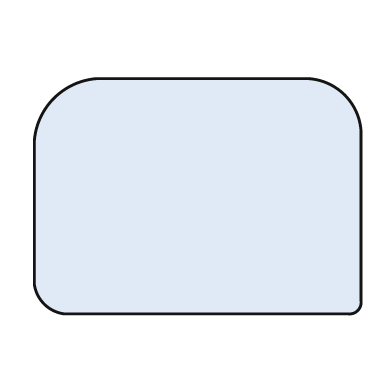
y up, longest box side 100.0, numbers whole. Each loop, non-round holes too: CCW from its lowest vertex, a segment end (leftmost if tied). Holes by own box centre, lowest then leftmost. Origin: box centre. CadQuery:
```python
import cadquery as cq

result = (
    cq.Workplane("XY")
    .moveTo(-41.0, -36.0)
    .lineTo(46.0, -36.0)
    .threePointArc((49.0, -35.0), (50.0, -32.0))
    .lineTo(50.0, 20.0)
    .threePointArc((45.0, 31.0), (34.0, 36.0))
    .lineTo(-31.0, 36.0)
    .threePointArc((-44.0, 30.0), (-50.0, 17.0))
    .lineTo(-50.0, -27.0)
    .threePointArc((-47.0, -33.0), (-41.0, -36.0))
    .close()
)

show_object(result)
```